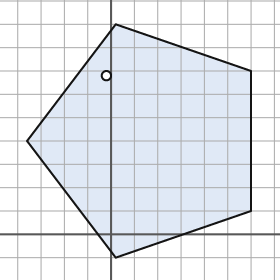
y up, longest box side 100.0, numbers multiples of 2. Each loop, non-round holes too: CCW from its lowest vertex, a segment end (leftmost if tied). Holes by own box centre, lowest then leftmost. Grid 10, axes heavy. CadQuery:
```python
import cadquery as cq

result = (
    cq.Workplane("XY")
    .moveTo(2.0, -10.0)
    .lineTo(60.0, 10.0)
    .lineTo(60.0, 70.0)
    .lineTo(2.0, 90.0)
    .lineTo(-36.0, 40.0)
    .close()
    .moveTo(-2.0, 68.0)
    .circle(2.0)
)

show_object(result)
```